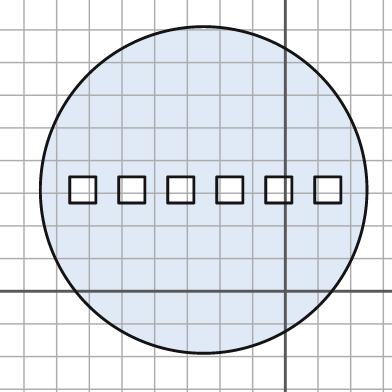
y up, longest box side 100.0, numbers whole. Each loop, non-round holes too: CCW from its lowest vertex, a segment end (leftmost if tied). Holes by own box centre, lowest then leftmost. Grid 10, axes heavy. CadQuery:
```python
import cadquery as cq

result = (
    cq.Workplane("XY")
    .moveTo(-25.0, 31.0)
    .circle(50.0)
    .moveTo(-66.0, 27.0)
    .lineTo(-58.0, 27.0)
    .lineTo(-58.0, 35.0)
    .lineTo(-66.0, 35.0)
    .close()
    .moveTo(-51.0, 27.0)
    .lineTo(-43.0, 27.0)
    .lineTo(-43.0, 35.0)
    .lineTo(-51.0, 35.0)
    .close()
    .moveTo(-36.0, 27.0)
    .lineTo(-28.0, 27.0)
    .lineTo(-28.0, 35.0)
    .lineTo(-36.0, 35.0)
    .close()
    .moveTo(-21.0, 27.0)
    .lineTo(-13.0, 27.0)
    .lineTo(-13.0, 35.0)
    .lineTo(-21.0, 35.0)
    .close()
    .moveTo(-6.0, 27.0)
    .lineTo(2.0, 27.0)
    .lineTo(2.0, 35.0)
    .lineTo(-6.0, 35.0)
    .close()
    .moveTo(9.0, 27.0)
    .lineTo(17.0, 27.0)
    .lineTo(17.0, 35.0)
    .lineTo(9.0, 35.0)
    .close()
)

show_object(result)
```